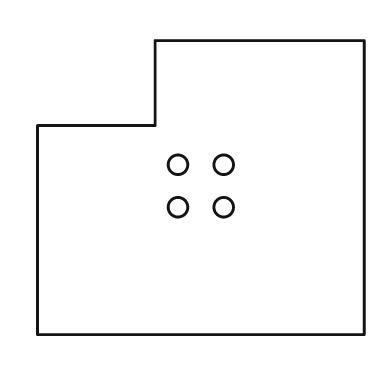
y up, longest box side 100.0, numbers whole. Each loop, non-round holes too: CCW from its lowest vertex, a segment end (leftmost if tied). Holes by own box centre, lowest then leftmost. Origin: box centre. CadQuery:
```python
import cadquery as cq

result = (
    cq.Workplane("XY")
    .moveTo(-50.0, -45.0)
    .lineTo(50.0, -45.0)
    .lineTo(50.0, 45.0)
    .lineTo(-14.0, 45.0)
    .lineTo(-14.0, 19.0)
    .lineTo(-50.0, 19.0)
    .close()
    .moveTo(-7.0, -6.0)
    .circle(3.0)
    .moveTo(7.0, -6.0)
    .circle(3.0)
    .moveTo(-7.0, 7.0)
    .circle(3.0)
    .moveTo(7.0, 7.0)
    .circle(3.0)
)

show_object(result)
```